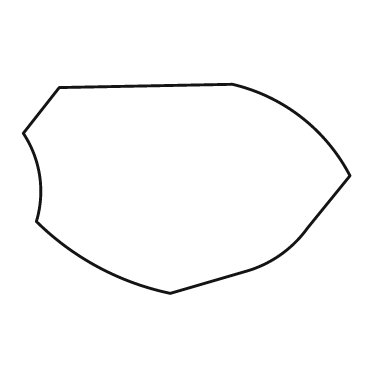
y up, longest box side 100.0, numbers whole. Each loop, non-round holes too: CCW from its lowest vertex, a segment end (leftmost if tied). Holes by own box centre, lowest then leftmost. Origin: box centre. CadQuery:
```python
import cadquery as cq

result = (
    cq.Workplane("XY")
    .moveTo(-5.0, -32.0)
    .lineTo(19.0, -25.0)
    .threePointArc((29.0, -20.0), (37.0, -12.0))
    .lineTo(50.0, 4.0)
    .threePointArc((35.0, 22.0), (14.0, 32.0))
    .lineTo(-39.0, 31.0)
    .lineTo(-50.0, 17.0)
    .threePointArc((-45.0, 4.0), (-46.0, -10.0))
    .threePointArc((-27.0, -24.0), (-5.0, -32.0))
    .close()
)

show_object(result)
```